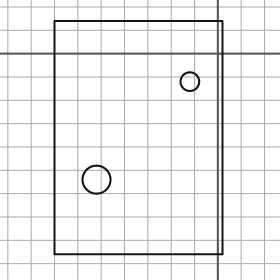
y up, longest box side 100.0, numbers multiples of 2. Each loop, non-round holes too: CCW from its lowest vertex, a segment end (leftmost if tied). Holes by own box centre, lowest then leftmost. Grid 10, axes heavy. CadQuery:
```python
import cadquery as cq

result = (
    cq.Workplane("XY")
    .moveTo(-70.0, -86.0)
    .lineTo(2.0, -86.0)
    .lineTo(2.0, 14.0)
    .lineTo(-70.0, 14.0)
    .close()
    .moveTo(-52.0, -54.0)
    .circle(6.0)
    .moveTo(-12.0, -12.0)
    .circle(4.0)
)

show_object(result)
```